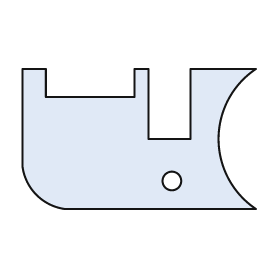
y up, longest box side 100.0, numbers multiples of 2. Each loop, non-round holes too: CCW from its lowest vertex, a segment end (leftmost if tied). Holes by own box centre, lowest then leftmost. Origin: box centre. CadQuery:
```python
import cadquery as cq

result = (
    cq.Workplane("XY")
    .moveTo(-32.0, -30.0)
    .lineTo(50.0, -30.0)
    .threePointArc((34.0, 0.0), (50.0, 30.0))
    .lineTo(22.0, 30.0)
    .lineTo(22.0, 0.0)
    .lineTo(4.0, 0.0)
    .lineTo(4.0, 30.0)
    .lineTo(-2.0, 30.0)
    .lineTo(-2.0, 18.0)
    .lineTo(-40.0, 18.0)
    .lineTo(-40.0, 30.0)
    .lineTo(-50.0, 30.0)
    .lineTo(-50.0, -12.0)
    .threePointArc((-44.0, -24.0), (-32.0, -30.0))
    .close()
    .moveTo(14.0, -18.0)
    .circle(4.0)
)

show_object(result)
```